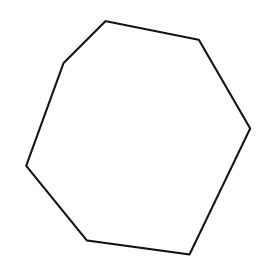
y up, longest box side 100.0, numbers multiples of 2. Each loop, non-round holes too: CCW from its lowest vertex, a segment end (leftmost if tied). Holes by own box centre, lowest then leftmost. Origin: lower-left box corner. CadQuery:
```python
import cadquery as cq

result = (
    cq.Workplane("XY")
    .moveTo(70.0, 0.0)
    .lineTo(96.0, 54.0)
    .lineTo(74.0, 92.0)
    .lineTo(34.0, 100.0)
    .lineTo(16.0, 82.0)
    .lineTo(0.0, 38.0)
    .lineTo(26.0, 6.0)
    .close()
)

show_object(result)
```